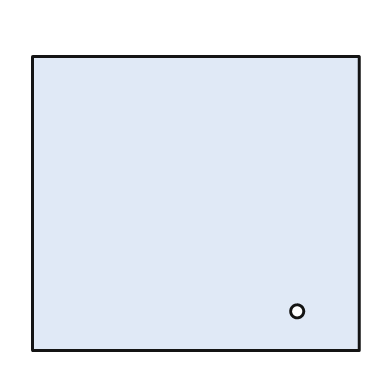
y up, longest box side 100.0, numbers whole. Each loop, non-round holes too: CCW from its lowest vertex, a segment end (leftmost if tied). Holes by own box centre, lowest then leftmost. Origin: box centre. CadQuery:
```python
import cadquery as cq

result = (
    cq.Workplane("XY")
    .moveTo(-50.0, -45.0)
    .lineTo(50.0, -45.0)
    .lineTo(50.0, 45.0)
    .lineTo(-50.0, 45.0)
    .close()
    .moveTo(31.0, -33.0)
    .circle(2.0)
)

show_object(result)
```